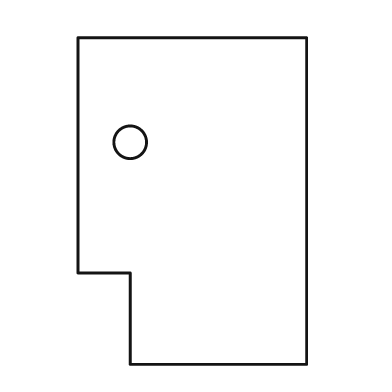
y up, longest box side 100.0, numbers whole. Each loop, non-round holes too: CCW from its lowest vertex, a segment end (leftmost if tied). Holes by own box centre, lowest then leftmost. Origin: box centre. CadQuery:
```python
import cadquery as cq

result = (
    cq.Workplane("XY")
    .moveTo(-19.0, -50.0)
    .lineTo(35.0, -50.0)
    .lineTo(35.0, 50.0)
    .lineTo(-35.0, 50.0)
    .lineTo(-35.0, -22.0)
    .lineTo(-19.0, -22.0)
    .close()
    .moveTo(-19.0, 18.0)
    .circle(5.0)
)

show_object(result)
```